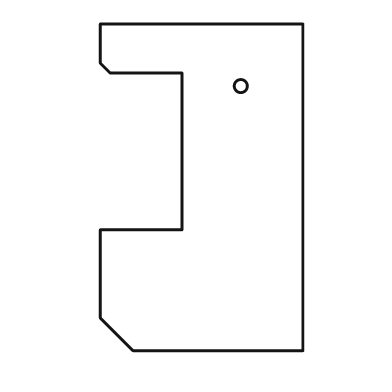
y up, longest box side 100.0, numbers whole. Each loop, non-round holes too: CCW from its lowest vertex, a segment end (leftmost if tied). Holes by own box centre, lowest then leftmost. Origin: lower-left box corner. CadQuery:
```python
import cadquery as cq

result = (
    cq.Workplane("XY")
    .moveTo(10.0, 0.0)
    .lineTo(62.0, 0.0)
    .lineTo(62.0, 100.0)
    .lineTo(0.0, 100.0)
    .lineTo(0.0, 88.0)
    .lineTo(3.0, 85.0)
    .lineTo(25.0, 85.0)
    .lineTo(25.0, 37.0)
    .lineTo(0.0, 37.0)
    .lineTo(0.0, 10.0)
    .close()
    .moveTo(43.0, 81.0)
    .circle(2.0)
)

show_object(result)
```